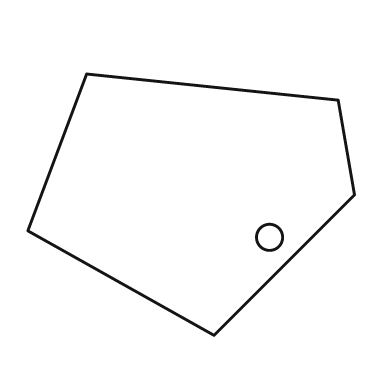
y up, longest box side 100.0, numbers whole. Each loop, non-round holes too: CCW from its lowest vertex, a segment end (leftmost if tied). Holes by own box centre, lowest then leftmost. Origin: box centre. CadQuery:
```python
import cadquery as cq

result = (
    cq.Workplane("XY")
    .moveTo(7.0, -40.0)
    .lineTo(50.0, 3.0)
    .lineTo(45.0, 32.0)
    .lineTo(-32.0, 40.0)
    .lineTo(-50.0, -8.0)
    .close()
    .moveTo(24.0, -10.0)
    .circle(4.0)
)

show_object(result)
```